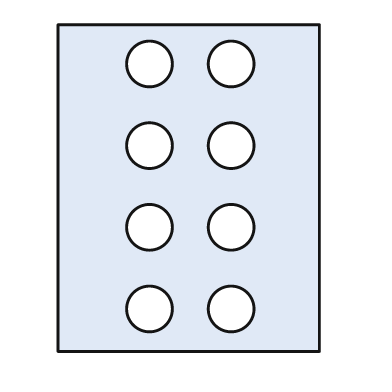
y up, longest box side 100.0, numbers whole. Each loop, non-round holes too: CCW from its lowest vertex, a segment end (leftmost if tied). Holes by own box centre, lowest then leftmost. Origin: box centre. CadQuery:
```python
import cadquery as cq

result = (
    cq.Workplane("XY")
    .moveTo(-40.0, -50.0)
    .lineTo(40.0, -50.0)
    .lineTo(40.0, 50.0)
    .lineTo(-40.0, 50.0)
    .close()
    .moveTo(-12.0, -37.0)
    .circle(7.0)
    .moveTo(13.0, -37.0)
    .circle(7.0)
    .moveTo(-12.0, -12.0)
    .circle(7.0)
    .moveTo(13.0, -12.0)
    .circle(7.0)
    .moveTo(-12.0, 13.0)
    .circle(7.0)
    .moveTo(13.0, 13.0)
    .circle(7.0)
    .moveTo(-12.0, 38.0)
    .circle(7.0)
    .moveTo(13.0, 38.0)
    .circle(7.0)
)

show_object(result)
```